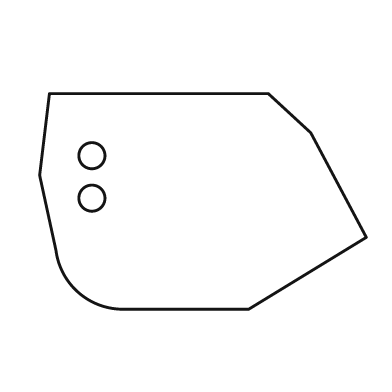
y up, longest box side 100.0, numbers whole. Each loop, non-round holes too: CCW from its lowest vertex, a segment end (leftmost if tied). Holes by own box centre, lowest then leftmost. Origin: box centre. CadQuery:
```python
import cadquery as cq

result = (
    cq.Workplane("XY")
    .moveTo(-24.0, -33.0)
    .lineTo(14.0, -33.0)
    .lineTo(50.0, -11.0)
    .lineTo(33.0, 21.0)
    .lineTo(20.0, 33.0)
    .lineTo(-47.0, 33.0)
    .lineTo(-50.0, 8.0)
    .lineTo(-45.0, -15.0)
    .threePointArc((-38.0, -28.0), (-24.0, -33.0))
    .close()
    .moveTo(-34.0, 1.0)
    .circle(4.0)
    .moveTo(-34.0, 14.0)
    .circle(4.0)
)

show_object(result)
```